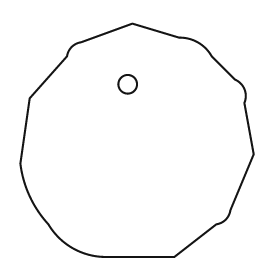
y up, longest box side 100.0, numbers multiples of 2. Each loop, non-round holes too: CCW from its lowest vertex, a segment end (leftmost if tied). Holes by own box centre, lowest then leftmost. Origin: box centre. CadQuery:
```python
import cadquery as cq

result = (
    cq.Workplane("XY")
    .moveTo(-14.0, -50.0)
    .lineTo(16.0, -50.0)
    .lineTo(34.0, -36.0)
    .threePointArc((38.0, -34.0), (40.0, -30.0))
    .lineTo(50.0, -6.0)
    .lineTo(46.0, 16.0)
    .threePointArc((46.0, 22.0), (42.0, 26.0))
    .lineTo(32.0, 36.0)
    .threePointArc((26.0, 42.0), (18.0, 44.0))
    .lineTo(-2.0, 50.0)
    .lineTo(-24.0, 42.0)
    .threePointArc((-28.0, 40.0), (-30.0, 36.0))
    .lineTo(-46.0, 18.0)
    .lineTo(-50.0, -10.0)
    .threePointArc((-46.0, -24.0), (-38.0, -36.0))
    .threePointArc((-28.0, -46.0), (-14.0, -50.0))
    .close()
    .moveTo(-4.0, 24.0)
    .circle(4.0)
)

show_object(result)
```